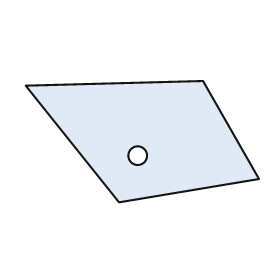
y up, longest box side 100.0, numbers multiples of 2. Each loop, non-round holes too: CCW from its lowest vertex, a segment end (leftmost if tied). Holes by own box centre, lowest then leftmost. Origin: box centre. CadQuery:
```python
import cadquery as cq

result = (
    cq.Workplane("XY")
    .moveTo(-10.0, -26.0)
    .lineTo(50.0, -16.0)
    .lineTo(26.0, 26.0)
    .lineTo(-50.0, 24.0)
    .close()
    .moveTo(-2.0, -6.0)
    .circle(4.0)
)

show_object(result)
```